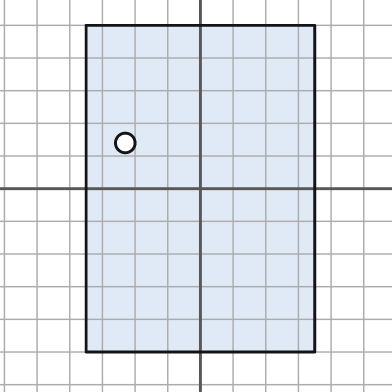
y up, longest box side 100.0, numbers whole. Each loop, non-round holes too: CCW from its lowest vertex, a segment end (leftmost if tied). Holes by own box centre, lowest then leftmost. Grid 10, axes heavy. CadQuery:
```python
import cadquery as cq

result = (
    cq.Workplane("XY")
    .moveTo(-35.0, -50.0)
    .lineTo(35.0, -50.0)
    .lineTo(35.0, 50.0)
    .lineTo(-35.0, 50.0)
    .close()
    .moveTo(-23.0, 14.0)
    .circle(3.0)
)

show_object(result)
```